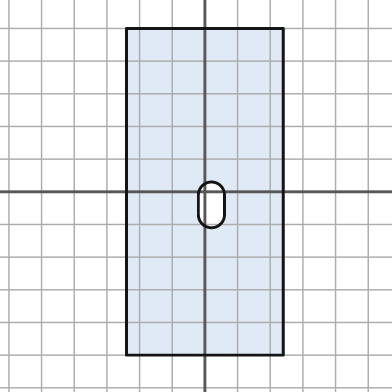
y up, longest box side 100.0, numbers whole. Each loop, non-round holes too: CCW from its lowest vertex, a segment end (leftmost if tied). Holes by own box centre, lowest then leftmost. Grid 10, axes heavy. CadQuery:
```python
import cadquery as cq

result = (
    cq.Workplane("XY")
    .moveTo(-24.0, -50.0)
    .lineTo(24.0, -50.0)
    .lineTo(24.0, 50.0)
    .lineTo(-24.0, 50.0)
    .close()
    .moveTo(-2.0, -7.0)
    .threePointArc((2.0, -11.0), (6.0, -7.0))
    .lineTo(6.0, -1.0)
    .threePointArc((2.0, 3.0), (-2.0, -1.0))
    .close()
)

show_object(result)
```